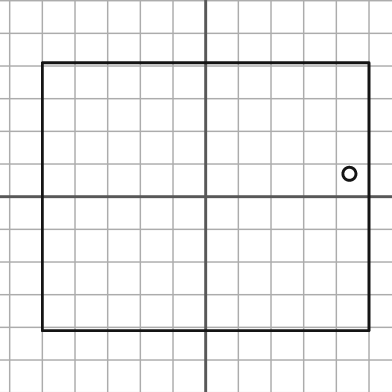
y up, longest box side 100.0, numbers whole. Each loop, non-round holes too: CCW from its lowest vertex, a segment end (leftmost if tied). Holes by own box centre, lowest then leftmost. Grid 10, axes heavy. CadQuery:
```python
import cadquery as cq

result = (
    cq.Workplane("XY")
    .moveTo(-50.0, -41.0)
    .lineTo(50.0, -41.0)
    .lineTo(50.0, 41.0)
    .lineTo(-50.0, 41.0)
    .close()
    .moveTo(44.0, 7.0)
    .circle(2.0)
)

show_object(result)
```